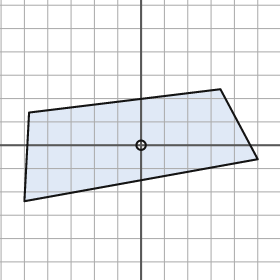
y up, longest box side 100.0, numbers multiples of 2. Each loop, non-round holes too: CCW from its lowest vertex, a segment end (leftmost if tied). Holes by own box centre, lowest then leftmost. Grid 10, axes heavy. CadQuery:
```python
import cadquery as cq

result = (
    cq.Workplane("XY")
    .moveTo(-50.0, -24.0)
    .lineTo(50.0, -6.0)
    .lineTo(34.0, 24.0)
    .lineTo(-48.0, 14.0)
    .close()
    .moveTo(0.0, 0.0)
    .circle(2.0)
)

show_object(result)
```